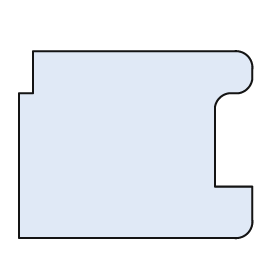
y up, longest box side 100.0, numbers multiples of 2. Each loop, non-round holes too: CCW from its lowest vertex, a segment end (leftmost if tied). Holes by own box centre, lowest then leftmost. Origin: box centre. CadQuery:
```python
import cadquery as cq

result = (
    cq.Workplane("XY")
    .moveTo(-50.0, -40.0)
    .lineTo(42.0, -40.0)
    .threePointArc((48.0, -38.0), (50.0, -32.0))
    .lineTo(50.0, -18.0)
    .lineTo(34.0, -18.0)
    .lineTo(34.0, 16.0)
    .threePointArc((36.0, 20.0), (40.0, 22.0))
    .lineTo(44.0, 22.0)
    .threePointArc((48.0, 24.0), (50.0, 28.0))
    .lineTo(50.0, 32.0)
    .threePointArc((48.0, 38.0), (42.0, 40.0))
    .lineTo(-44.0, 40.0)
    .lineTo(-44.0, 22.0)
    .lineTo(-50.0, 22.0)
    .close()
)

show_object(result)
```